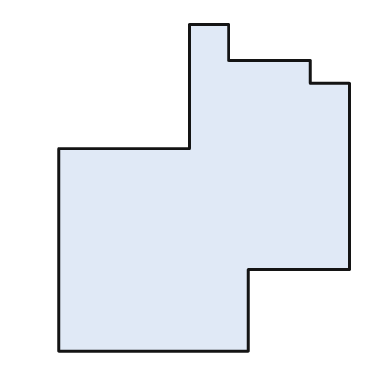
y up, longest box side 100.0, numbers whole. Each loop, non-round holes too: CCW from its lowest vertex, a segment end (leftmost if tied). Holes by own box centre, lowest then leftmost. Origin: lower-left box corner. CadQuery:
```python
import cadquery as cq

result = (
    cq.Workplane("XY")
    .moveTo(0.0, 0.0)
    .lineTo(58.0, 0.0)
    .lineTo(58.0, 25.0)
    .lineTo(89.0, 25.0)
    .lineTo(89.0, 82.0)
    .lineTo(77.0, 82.0)
    .lineTo(77.0, 89.0)
    .lineTo(52.0, 89.0)
    .lineTo(52.0, 100.0)
    .lineTo(40.0, 100.0)
    .lineTo(40.0, 62.0)
    .lineTo(0.0, 62.0)
    .close()
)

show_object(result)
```